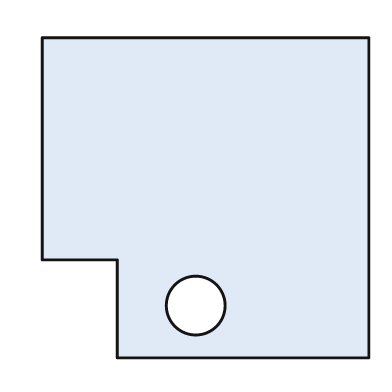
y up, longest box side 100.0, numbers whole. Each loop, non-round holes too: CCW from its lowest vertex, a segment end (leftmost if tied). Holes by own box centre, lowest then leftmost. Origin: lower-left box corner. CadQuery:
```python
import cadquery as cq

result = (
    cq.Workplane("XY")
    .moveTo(23.0, 0.0)
    .lineTo(100.0, 0.0)
    .lineTo(100.0, 98.0)
    .lineTo(0.0, 98.0)
    .lineTo(0.0, 30.0)
    .lineTo(23.0, 30.0)
    .close()
    .moveTo(47.0, 16.0)
    .circle(9.0)
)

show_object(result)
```